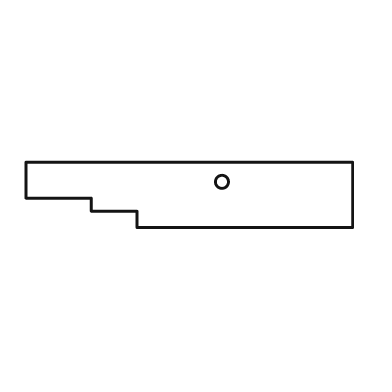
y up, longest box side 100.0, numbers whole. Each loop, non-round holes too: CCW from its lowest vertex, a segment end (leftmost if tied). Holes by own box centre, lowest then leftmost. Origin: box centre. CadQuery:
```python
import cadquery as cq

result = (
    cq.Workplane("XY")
    .moveTo(-16.0, -10.0)
    .lineTo(50.0, -10.0)
    .lineTo(50.0, 10.0)
    .lineTo(-50.0, 10.0)
    .lineTo(-50.0, -1.0)
    .lineTo(-30.0, -1.0)
    .lineTo(-30.0, -5.0)
    .lineTo(-16.0, -5.0)
    .close()
    .moveTo(10.0, 4.0)
    .circle(2.0)
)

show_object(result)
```